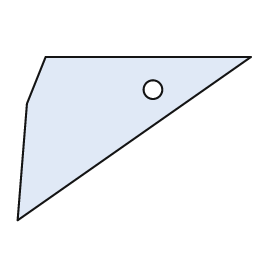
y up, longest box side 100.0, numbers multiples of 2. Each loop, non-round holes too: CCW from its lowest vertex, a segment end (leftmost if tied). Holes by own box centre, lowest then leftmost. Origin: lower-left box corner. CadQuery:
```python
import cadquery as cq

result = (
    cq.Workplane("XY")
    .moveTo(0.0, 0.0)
    .lineTo(100.0, 70.0)
    .lineTo(12.0, 70.0)
    .lineTo(4.0, 50.0)
    .close()
    .moveTo(58.0, 56.0)
    .circle(4.0)
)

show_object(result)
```